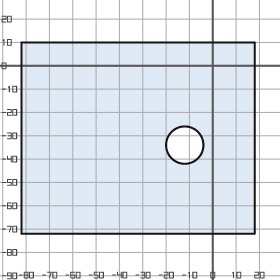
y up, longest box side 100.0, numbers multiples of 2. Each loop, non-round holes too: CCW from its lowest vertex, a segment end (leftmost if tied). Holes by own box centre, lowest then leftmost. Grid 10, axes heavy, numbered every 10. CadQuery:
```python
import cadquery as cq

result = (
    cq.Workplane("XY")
    .moveTo(-82.0, -72.0)
    .lineTo(18.0, -72.0)
    .lineTo(18.0, 10.0)
    .lineTo(-82.0, 10.0)
    .close()
    .moveTo(-12.0, -34.0)
    .circle(8.0)
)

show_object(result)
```